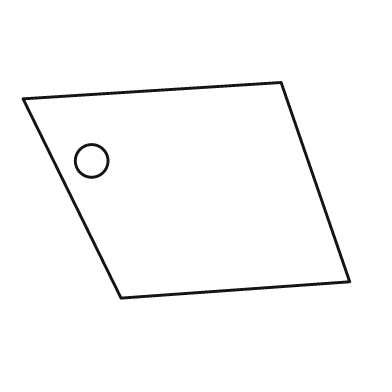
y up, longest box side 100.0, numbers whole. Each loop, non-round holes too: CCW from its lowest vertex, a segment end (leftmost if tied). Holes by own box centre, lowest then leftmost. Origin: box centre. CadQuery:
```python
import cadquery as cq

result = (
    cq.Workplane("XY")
    .moveTo(-20.0, -33.0)
    .lineTo(50.0, -28.0)
    .lineTo(29.0, 33.0)
    .lineTo(-50.0, 28.0)
    .close()
    .moveTo(-29.0, 9.0)
    .circle(5.0)
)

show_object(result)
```